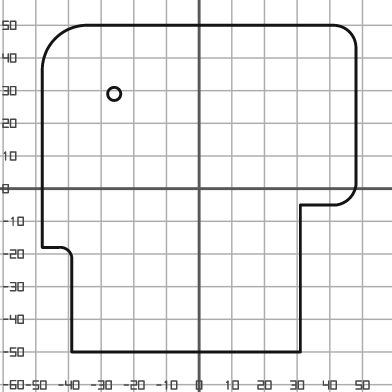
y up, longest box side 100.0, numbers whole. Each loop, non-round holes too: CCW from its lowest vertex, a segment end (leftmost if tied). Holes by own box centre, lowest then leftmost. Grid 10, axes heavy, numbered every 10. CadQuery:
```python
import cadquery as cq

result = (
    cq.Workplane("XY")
    .moveTo(-39.0, -50.0)
    .lineTo(31.0, -50.0)
    .lineTo(31.0, -5.0)
    .lineTo(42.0, -5.0)
    .threePointArc((46.0, -3.0), (48.0, 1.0))
    .lineTo(48.0, 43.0)
    .threePointArc((46.0, 48.0), (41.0, 50.0))
    .lineTo(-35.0, 50.0)
    .threePointArc((-44.0, 46.0), (-48.0, 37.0))
    .lineTo(-48.0, -18.0)
    .lineTo(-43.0, -18.0)
    .threePointArc((-40.0, -19.0), (-39.0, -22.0))
    .close()
    .moveTo(-26.0, 29.0)
    .circle(2.0)
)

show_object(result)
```